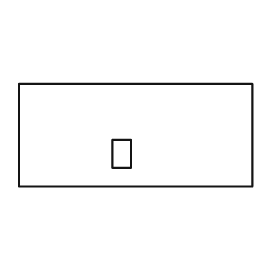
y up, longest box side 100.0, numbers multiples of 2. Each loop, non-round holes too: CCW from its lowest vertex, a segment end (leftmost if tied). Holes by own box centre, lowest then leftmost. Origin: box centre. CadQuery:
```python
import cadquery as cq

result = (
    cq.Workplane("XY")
    .moveTo(-50.0, -22.0)
    .lineTo(50.0, -22.0)
    .lineTo(50.0, 22.0)
    .lineTo(-50.0, 22.0)
    .close()
    .moveTo(-10.0, -14.0)
    .lineTo(-2.0, -14.0)
    .lineTo(-2.0, -2.0)
    .lineTo(-10.0, -2.0)
    .close()
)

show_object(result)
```